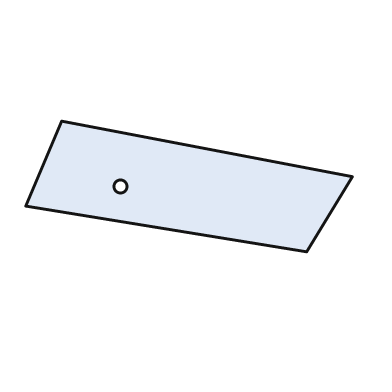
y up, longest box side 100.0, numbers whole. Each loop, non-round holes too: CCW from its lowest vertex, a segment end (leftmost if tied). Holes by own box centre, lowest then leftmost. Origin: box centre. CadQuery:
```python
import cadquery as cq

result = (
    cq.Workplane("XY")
    .moveTo(36.0, -20.0)
    .lineTo(50.0, 3.0)
    .lineTo(-39.0, 20.0)
    .lineTo(-50.0, -6.0)
    .close()
    .moveTo(-21.0, 0.0)
    .circle(2.0)
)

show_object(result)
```